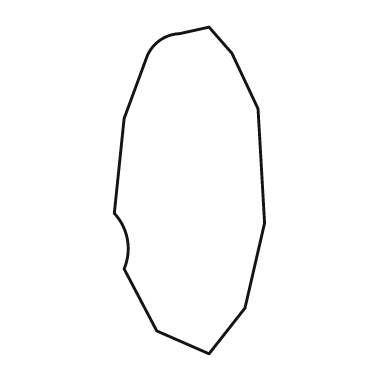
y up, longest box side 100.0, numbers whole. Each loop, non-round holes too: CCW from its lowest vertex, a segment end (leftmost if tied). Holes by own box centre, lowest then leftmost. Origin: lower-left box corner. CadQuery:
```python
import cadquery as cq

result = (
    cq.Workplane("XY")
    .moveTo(29.0, 0.0)
    .lineTo(40.0, 14.0)
    .lineTo(46.0, 40.0)
    .lineTo(44.0, 75.0)
    .lineTo(36.0, 92.0)
    .lineTo(29.0, 100.0)
    .lineTo(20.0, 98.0)
    .threePointArc((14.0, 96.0), (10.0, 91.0))
    .lineTo(3.0, 72.0)
    .lineTo(0.0, 43.0)
    .threePointArc((4.0, 35.0), (3.0, 26.0))
    .lineTo(13.0, 7.0)
    .close()
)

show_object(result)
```